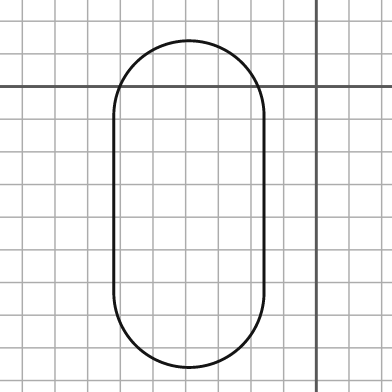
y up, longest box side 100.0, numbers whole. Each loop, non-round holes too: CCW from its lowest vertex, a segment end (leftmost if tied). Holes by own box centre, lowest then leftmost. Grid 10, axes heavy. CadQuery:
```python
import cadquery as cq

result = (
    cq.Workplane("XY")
    .moveTo(-62.0, -63.0)
    .threePointArc((-39.0, -86.0), (-16.0, -63.0))
    .lineTo(-16.0, -9.0)
    .threePointArc((-39.0, 14.0), (-62.0, -9.0))
    .close()
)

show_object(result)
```